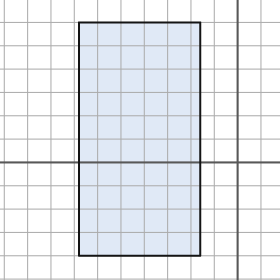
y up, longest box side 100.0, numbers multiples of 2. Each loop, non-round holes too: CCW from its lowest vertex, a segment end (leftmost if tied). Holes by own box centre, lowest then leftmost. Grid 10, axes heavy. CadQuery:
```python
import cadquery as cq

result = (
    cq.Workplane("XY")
    .moveTo(-68.0, -40.0)
    .lineTo(-16.0, -40.0)
    .lineTo(-16.0, 60.0)
    .lineTo(-68.0, 60.0)
    .close()
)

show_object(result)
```